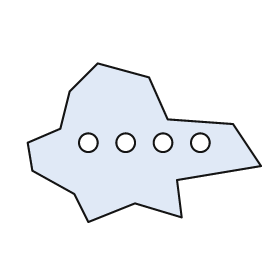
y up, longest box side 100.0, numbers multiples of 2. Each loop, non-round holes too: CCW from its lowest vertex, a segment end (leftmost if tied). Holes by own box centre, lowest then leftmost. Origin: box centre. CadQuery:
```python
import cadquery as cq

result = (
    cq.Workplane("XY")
    .moveTo(-24.0, -34.0)
    .lineTo(-4.0, -26.0)
    .lineTo(16.0, -32.0)
    .lineTo(14.0, -16.0)
    .lineTo(50.0, -10.0)
    .lineTo(38.0, 8.0)
    .lineTo(10.0, 10.0)
    .lineTo(2.0, 28.0)
    .lineTo(-20.0, 34.0)
    .lineTo(-32.0, 22.0)
    .lineTo(-36.0, 6.0)
    .lineTo(-50.0, 0.0)
    .lineTo(-48.0, -12.0)
    .lineTo(-30.0, -22.0)
    .close()
    .moveTo(-24.0, 0.0)
    .circle(4.0)
    .moveTo(-8.0, 0.0)
    .circle(4.0)
    .moveTo(8.0, 0.0)
    .circle(4.0)
    .moveTo(24.0, 0.0)
    .circle(4.0)
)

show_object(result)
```